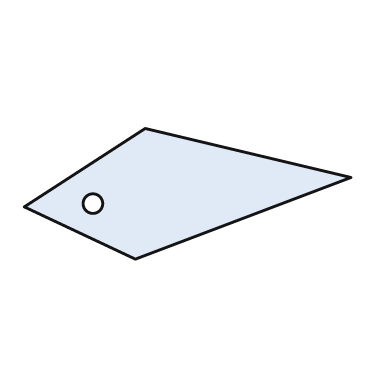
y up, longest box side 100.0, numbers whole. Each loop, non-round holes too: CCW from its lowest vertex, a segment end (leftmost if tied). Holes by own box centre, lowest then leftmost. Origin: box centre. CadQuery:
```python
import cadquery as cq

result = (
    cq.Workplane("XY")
    .moveTo(-16.0, -20.0)
    .lineTo(50.0, 5.0)
    .lineTo(-13.0, 20.0)
    .lineTo(-50.0, -4.0)
    .close()
    .moveTo(-29.0, -3.0)
    .circle(3.0)
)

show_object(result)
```